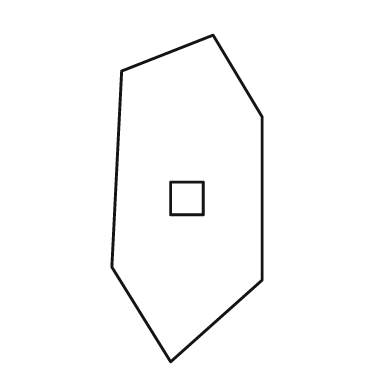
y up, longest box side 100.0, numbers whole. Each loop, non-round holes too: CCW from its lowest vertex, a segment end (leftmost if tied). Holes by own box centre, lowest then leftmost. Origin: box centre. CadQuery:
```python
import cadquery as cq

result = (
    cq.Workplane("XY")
    .moveTo(-5.0, -50.0)
    .lineTo(23.0, -25.0)
    .lineTo(23.0, 25.0)
    .lineTo(8.0, 50.0)
    .lineTo(-20.0, 39.0)
    .lineTo(-23.0, -21.0)
    .close()
    .moveTo(-5.0, -5.0)
    .lineTo(5.0, -5.0)
    .lineTo(5.0, 5.0)
    .lineTo(-5.0, 5.0)
    .close()
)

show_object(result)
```